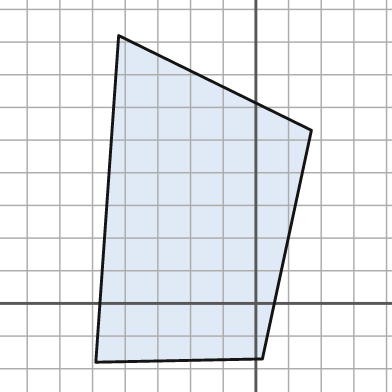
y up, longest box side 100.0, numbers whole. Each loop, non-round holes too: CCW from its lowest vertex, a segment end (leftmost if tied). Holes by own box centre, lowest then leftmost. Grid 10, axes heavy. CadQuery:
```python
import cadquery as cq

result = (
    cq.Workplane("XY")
    .moveTo(-49.0, -18.0)
    .lineTo(2.0, -17.0)
    .lineTo(17.0, 53.0)
    .lineTo(-42.0, 82.0)
    .close()
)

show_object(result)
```